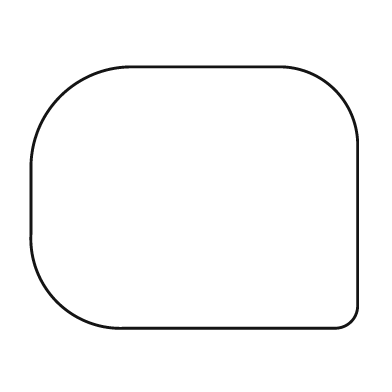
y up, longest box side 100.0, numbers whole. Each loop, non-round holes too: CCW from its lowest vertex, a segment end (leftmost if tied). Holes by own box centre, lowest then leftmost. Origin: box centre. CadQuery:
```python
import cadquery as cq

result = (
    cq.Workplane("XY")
    .moveTo(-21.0, -40.0)
    .lineTo(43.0, -40.0)
    .threePointArc((48.0, -38.0), (50.0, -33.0))
    .lineTo(50.0, 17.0)
    .threePointArc((43.0, 33.0), (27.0, 40.0))
    .lineTo(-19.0, 40.0)
    .threePointArc((-41.0, 31.0), (-50.0, 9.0))
    .lineTo(-50.0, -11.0)
    .threePointArc((-42.0, -32.0), (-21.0, -40.0))
    .close()
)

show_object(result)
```